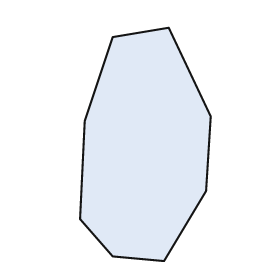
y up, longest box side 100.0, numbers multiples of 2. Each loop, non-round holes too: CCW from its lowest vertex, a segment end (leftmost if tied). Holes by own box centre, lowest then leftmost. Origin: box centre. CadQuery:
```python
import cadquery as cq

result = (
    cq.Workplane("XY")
    .moveTo(8.0, -50.0)
    .lineTo(26.0, -20.0)
    .lineTo(28.0, 12.0)
    .lineTo(10.0, 50.0)
    .lineTo(-14.0, 46.0)
    .lineTo(-26.0, 10.0)
    .lineTo(-28.0, -32.0)
    .lineTo(-14.0, -48.0)
    .close()
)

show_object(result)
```